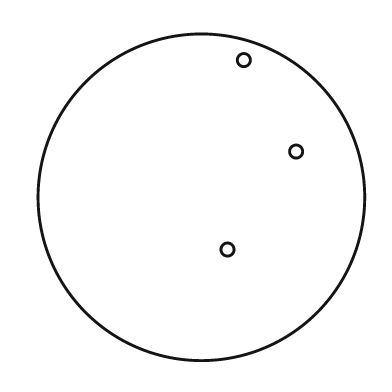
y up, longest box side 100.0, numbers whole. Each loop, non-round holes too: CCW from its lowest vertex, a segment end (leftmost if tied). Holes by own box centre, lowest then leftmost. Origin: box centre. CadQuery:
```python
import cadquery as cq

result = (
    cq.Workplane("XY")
    .moveTo(0.0, 0.0)
    .circle(50.0)
    .moveTo(8.0, -16.0)
    .circle(2.0)
    .moveTo(29.0, 14.0)
    .circle(2.0)
    .moveTo(13.0, 42.0)
    .circle(2.0)
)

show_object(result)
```